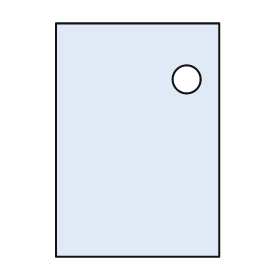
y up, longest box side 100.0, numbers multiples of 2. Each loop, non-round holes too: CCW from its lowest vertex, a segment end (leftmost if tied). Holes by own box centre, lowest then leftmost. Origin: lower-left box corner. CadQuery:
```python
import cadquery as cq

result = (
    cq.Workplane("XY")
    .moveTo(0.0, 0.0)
    .lineTo(70.0, 0.0)
    .lineTo(70.0, 100.0)
    .lineTo(0.0, 100.0)
    .close()
    .moveTo(56.0, 76.0)
    .circle(6.0)
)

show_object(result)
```